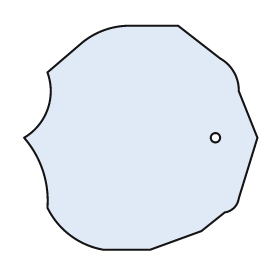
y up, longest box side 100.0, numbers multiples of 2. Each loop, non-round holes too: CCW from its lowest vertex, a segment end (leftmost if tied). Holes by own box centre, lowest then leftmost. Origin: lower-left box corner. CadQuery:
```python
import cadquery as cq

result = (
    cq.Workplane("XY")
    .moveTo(34.0, 0.0)
    .lineTo(54.0, 0.0)
    .lineTo(76.0, 8.0)
    .lineTo(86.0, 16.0)
    .threePointArc((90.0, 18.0), (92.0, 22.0))
    .lineTo(100.0, 48.0)
    .lineTo(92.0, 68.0)
    .threePointArc((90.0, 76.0), (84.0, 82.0))
    .lineTo(66.0, 96.0)
    .lineTo(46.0, 96.0)
    .threePointArc((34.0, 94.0), (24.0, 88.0))
    .lineTo(10.0, 76.0)
    .threePointArc((10.0, 60.0), (0.0, 48.0))
    .threePointArc((8.0, 34.0), (10.0, 18.0))
    .threePointArc((20.0, 6.0), (34.0, 0.0))
    .close()
    .moveTo(82.0, 48.0)
    .circle(2.0)
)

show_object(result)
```